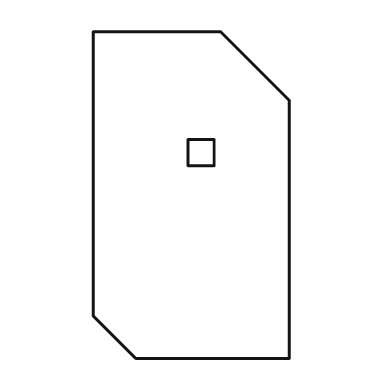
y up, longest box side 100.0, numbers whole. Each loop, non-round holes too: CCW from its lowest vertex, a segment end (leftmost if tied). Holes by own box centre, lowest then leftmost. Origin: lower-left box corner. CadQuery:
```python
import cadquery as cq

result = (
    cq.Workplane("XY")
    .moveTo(13.0, 0.0)
    .lineTo(60.0, 0.0)
    .lineTo(60.0, 79.0)
    .lineTo(39.0, 100.0)
    .lineTo(0.0, 100.0)
    .lineTo(0.0, 13.0)
    .close()
    .moveTo(29.0, 59.0)
    .lineTo(37.0, 59.0)
    .lineTo(37.0, 67.0)
    .lineTo(29.0, 67.0)
    .close()
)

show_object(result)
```